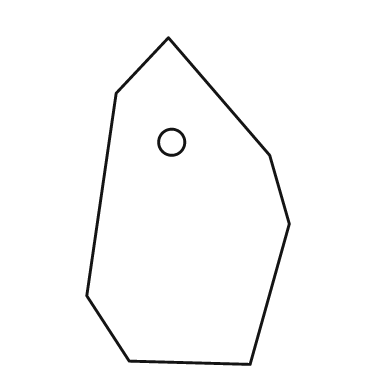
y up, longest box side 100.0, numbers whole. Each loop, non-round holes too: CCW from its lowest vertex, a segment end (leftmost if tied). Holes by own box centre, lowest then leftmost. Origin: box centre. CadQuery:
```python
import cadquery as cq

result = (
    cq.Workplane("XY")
    .moveTo(19.0, -50.0)
    .lineTo(31.0, -7.0)
    .lineTo(25.0, 14.0)
    .lineTo(-6.0, 50.0)
    .lineTo(-22.0, 33.0)
    .lineTo(-31.0, -29.0)
    .lineTo(-18.0, -49.0)
    .close()
    .moveTo(-5.0, 18.0)
    .circle(4.0)
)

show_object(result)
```